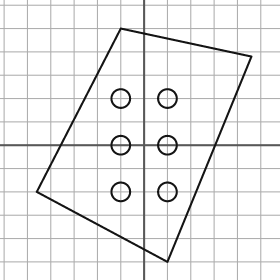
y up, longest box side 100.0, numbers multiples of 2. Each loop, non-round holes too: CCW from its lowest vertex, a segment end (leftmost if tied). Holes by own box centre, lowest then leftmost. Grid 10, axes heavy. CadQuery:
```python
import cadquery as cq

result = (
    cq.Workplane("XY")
    .moveTo(10.0, -50.0)
    .lineTo(46.0, 38.0)
    .lineTo(-10.0, 50.0)
    .lineTo(-46.0, -20.0)
    .close()
    .moveTo(-10.0, -20.0)
    .circle(4.0)
    .moveTo(10.0, -20.0)
    .circle(4.0)
    .moveTo(-10.0, 0.0)
    .circle(4.0)
    .moveTo(10.0, 0.0)
    .circle(4.0)
    .moveTo(-10.0, 20.0)
    .circle(4.0)
    .moveTo(10.0, 20.0)
    .circle(4.0)
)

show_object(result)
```